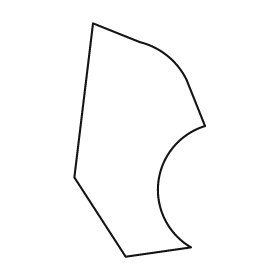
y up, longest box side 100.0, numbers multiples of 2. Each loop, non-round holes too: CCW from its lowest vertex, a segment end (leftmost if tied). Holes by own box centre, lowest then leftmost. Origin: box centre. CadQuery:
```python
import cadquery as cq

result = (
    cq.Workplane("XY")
    .moveTo(-6.0, -50.0)
    .lineTo(22.0, -46.0)
    .threePointArc((8.0, -18.0), (28.0, 6.0))
    .lineTo(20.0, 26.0)
    .threePointArc((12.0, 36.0), (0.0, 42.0))
    .lineTo(-20.0, 50.0)
    .lineTo(-28.0, -16.0)
    .close()
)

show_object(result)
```